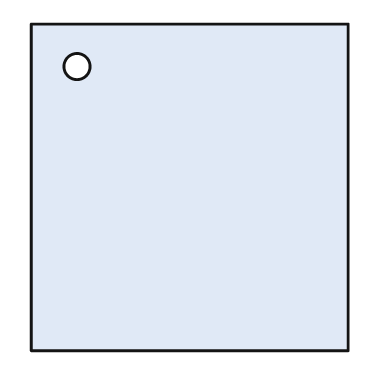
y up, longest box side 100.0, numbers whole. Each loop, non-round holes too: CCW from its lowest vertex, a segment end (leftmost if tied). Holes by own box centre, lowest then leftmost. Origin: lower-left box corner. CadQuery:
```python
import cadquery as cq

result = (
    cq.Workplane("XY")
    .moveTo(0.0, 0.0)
    .lineTo(97.0, 0.0)
    .lineTo(97.0, 100.0)
    .lineTo(0.0, 100.0)
    .close()
    .moveTo(14.0, 87.0)
    .circle(4.0)
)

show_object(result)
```